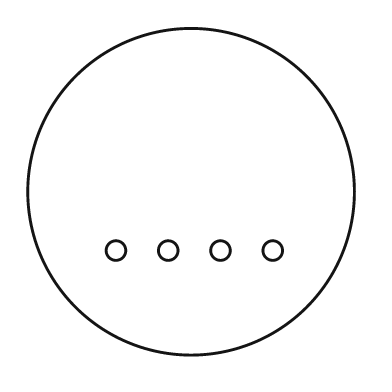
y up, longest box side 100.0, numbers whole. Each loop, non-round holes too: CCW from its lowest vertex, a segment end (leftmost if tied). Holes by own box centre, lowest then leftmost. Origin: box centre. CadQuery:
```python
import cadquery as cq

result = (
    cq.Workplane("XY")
    .moveTo(0.0, 0.0)
    .circle(50.0)
    .moveTo(-23.0, -18.0)
    .circle(3.0)
    .moveTo(-7.0, -18.0)
    .circle(3.0)
    .moveTo(9.0, -18.0)
    .circle(3.0)
    .moveTo(25.0, -18.0)
    .circle(3.0)
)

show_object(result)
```